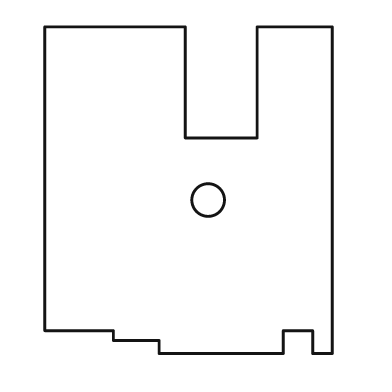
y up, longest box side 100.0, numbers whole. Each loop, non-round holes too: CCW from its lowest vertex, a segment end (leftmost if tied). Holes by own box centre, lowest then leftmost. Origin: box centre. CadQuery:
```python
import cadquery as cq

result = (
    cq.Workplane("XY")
    .moveTo(-9.0, -50.0)
    .lineTo(29.0, -50.0)
    .lineTo(29.0, -43.0)
    .lineTo(38.0, -43.0)
    .lineTo(38.0, -50.0)
    .lineTo(44.0, -50.0)
    .lineTo(44.0, 50.0)
    .lineTo(21.0, 50.0)
    .lineTo(21.0, 16.0)
    .lineTo(-1.0, 16.0)
    .lineTo(-1.0, 50.0)
    .lineTo(-44.0, 50.0)
    .lineTo(-44.0, -43.0)
    .lineTo(-23.0, -43.0)
    .lineTo(-23.0, -46.0)
    .lineTo(-9.0, -46.0)
    .close()
    .moveTo(6.0, -3.0)
    .circle(5.0)
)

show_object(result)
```